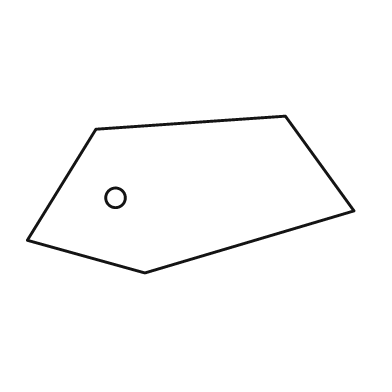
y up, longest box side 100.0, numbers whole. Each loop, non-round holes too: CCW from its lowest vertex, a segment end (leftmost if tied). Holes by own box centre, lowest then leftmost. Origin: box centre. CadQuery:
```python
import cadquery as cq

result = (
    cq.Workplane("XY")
    .moveTo(-14.0, -24.0)
    .lineTo(50.0, -5.0)
    .lineTo(29.0, 24.0)
    .lineTo(-29.0, 20.0)
    .lineTo(-50.0, -14.0)
    .close()
    .moveTo(-23.0, -1.0)
    .circle(3.0)
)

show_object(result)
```